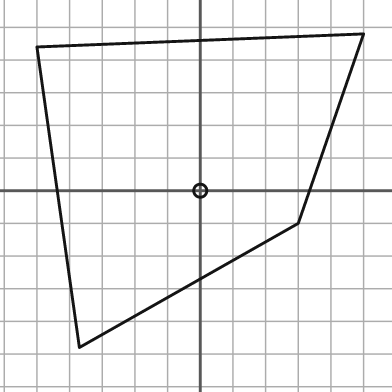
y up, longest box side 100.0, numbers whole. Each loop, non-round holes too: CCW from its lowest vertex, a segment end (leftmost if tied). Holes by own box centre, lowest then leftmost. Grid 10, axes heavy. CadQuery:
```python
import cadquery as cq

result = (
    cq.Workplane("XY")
    .moveTo(-37.0, -48.0)
    .lineTo(30.0, -10.0)
    .lineTo(50.0, 48.0)
    .lineTo(-50.0, 44.0)
    .close()
    .moveTo(0.0, 0.0)
    .circle(2.0)
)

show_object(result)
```